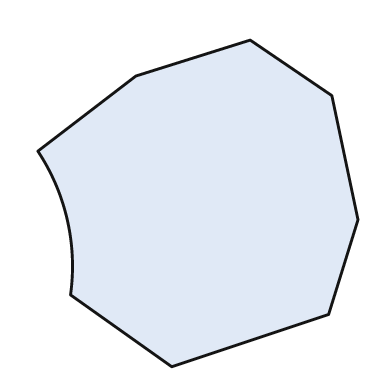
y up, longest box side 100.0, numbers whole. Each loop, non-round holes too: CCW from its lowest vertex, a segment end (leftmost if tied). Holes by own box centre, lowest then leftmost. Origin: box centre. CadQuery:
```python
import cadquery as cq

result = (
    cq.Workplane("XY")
    .moveTo(-8.0, -50.0)
    .lineTo(40.0, -34.0)
    .lineTo(49.0, -5.0)
    .lineTo(41.0, 33.0)
    .lineTo(16.0, 50.0)
    .lineTo(-19.0, 39.0)
    .lineTo(-49.0, 16.0)
    .threePointArc((-40.0, -5.0), (-39.0, -28.0))
    .close()
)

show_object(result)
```